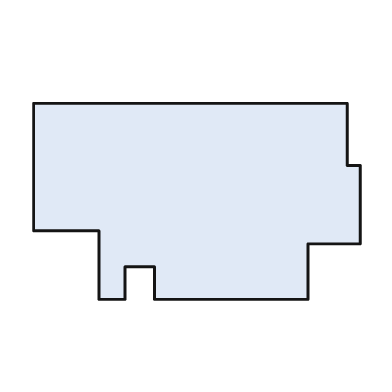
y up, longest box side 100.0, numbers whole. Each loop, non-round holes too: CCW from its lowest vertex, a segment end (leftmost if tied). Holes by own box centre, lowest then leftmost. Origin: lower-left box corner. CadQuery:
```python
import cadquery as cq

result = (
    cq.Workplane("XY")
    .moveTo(20.0, 0.0)
    .lineTo(28.0, 0.0)
    .lineTo(28.0, 10.0)
    .lineTo(37.0, 10.0)
    .lineTo(37.0, 0.0)
    .lineTo(84.0, 0.0)
    .lineTo(84.0, 17.0)
    .lineTo(100.0, 17.0)
    .lineTo(100.0, 41.0)
    .lineTo(96.0, 41.0)
    .lineTo(96.0, 60.0)
    .lineTo(0.0, 60.0)
    .lineTo(0.0, 21.0)
    .lineTo(20.0, 21.0)
    .close()
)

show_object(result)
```